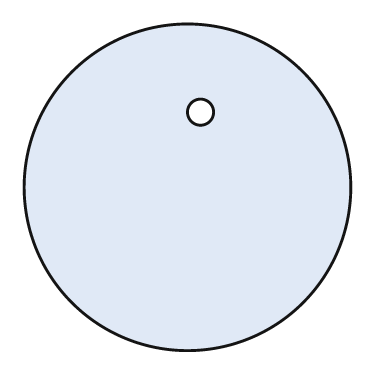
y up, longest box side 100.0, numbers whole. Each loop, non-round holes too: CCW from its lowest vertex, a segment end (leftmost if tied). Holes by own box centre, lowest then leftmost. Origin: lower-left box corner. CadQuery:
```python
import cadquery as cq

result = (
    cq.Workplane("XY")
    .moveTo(50.0, 50.0)
    .circle(50.0)
    .moveTo(54.0, 73.0)
    .circle(4.0)
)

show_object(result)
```